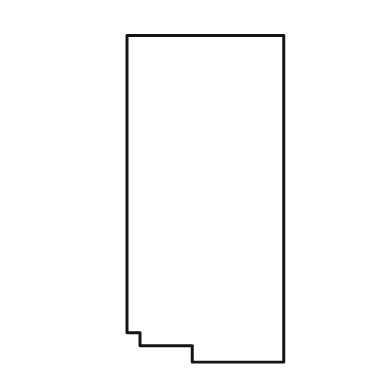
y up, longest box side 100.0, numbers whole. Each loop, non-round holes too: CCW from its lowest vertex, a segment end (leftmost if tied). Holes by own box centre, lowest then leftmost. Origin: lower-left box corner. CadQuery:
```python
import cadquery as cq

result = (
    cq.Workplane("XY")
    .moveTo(20.0, 0.0)
    .lineTo(48.0, 0.0)
    .lineTo(48.0, 100.0)
    .lineTo(0.0, 100.0)
    .lineTo(0.0, 9.0)
    .lineTo(4.0, 9.0)
    .lineTo(4.0, 5.0)
    .lineTo(20.0, 5.0)
    .close()
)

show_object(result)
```